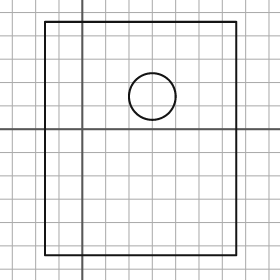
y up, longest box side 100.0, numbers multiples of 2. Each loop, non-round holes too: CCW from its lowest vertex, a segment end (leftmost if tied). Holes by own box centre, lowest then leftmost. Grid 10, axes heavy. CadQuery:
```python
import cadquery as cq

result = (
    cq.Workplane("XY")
    .moveTo(-16.0, -54.0)
    .lineTo(66.0, -54.0)
    .lineTo(66.0, 46.0)
    .lineTo(-16.0, 46.0)
    .close()
    .moveTo(30.0, 14.0)
    .circle(10.0)
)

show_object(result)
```